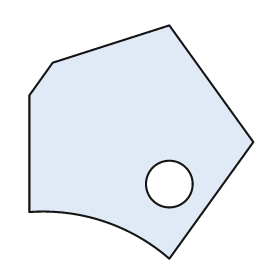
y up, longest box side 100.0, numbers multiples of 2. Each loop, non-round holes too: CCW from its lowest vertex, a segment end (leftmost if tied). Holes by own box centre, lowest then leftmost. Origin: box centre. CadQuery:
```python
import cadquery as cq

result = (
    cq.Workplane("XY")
    .moveTo(12.0, -50.0)
    .lineTo(48.0, 0.0)
    .lineTo(12.0, 50.0)
    .lineTo(-38.0, 34.0)
    .lineTo(-48.0, 20.0)
    .lineTo(-48.0, -30.0)
    .threePointArc((-16.0, -34.0), (12.0, -50.0))
    .close()
    .moveTo(12.0, -18.0)
    .circle(10.0)
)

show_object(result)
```